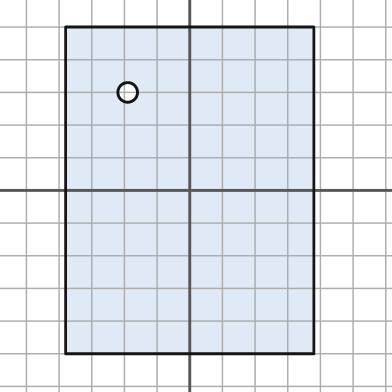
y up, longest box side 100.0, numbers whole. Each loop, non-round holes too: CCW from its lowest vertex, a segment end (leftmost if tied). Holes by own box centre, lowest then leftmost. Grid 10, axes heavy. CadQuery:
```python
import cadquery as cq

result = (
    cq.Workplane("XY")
    .moveTo(-38.0, -50.0)
    .lineTo(38.0, -50.0)
    .lineTo(38.0, 50.0)
    .lineTo(-38.0, 50.0)
    .close()
    .moveTo(-19.0, 30.0)
    .circle(3.0)
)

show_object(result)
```